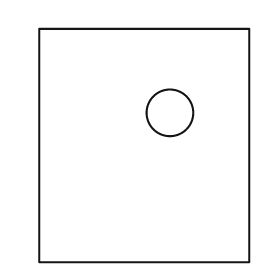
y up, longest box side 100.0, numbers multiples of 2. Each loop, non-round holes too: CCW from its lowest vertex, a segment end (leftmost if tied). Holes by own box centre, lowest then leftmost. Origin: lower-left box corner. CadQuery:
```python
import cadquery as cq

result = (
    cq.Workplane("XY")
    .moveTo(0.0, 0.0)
    .lineTo(90.0, 0.0)
    .lineTo(90.0, 100.0)
    .lineTo(0.0, 100.0)
    .close()
    .moveTo(56.0, 64.0)
    .circle(10.0)
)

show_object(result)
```